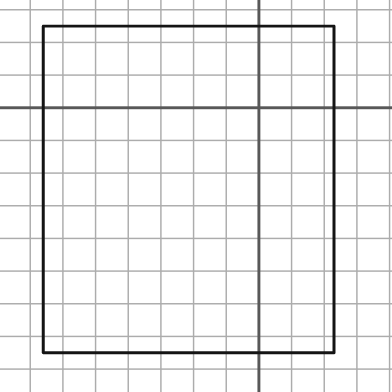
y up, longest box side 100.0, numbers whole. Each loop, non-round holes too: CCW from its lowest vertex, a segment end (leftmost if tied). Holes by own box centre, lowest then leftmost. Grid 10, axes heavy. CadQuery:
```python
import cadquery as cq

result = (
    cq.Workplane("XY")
    .moveTo(-66.0, -75.0)
    .lineTo(23.0, -75.0)
    .lineTo(23.0, 25.0)
    .lineTo(-66.0, 25.0)
    .close()
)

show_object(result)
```